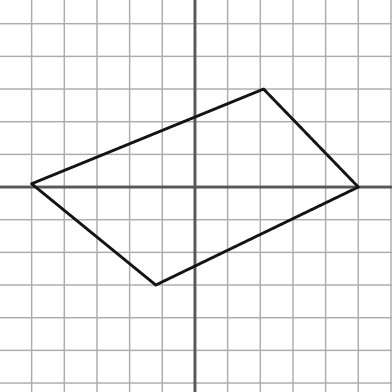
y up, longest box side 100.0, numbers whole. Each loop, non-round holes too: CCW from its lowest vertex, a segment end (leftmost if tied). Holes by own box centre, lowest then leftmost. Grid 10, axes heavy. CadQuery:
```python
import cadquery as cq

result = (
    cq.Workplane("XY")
    .moveTo(-12.0, -30.0)
    .lineTo(50.0, 0.0)
    .lineTo(21.0, 30.0)
    .lineTo(-50.0, 1.0)
    .close()
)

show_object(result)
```